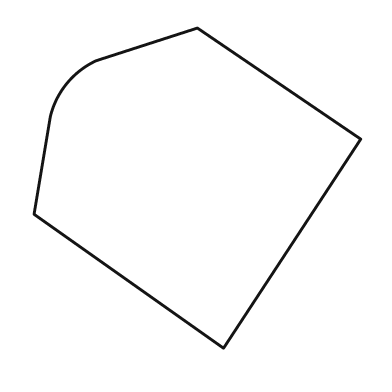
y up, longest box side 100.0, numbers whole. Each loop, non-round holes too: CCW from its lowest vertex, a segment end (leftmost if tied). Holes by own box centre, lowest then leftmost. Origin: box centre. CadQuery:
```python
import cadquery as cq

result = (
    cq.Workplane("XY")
    .moveTo(8.0, -49.0)
    .lineTo(50.0, 15.0)
    .lineTo(0.0, 49.0)
    .lineTo(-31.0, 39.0)
    .threePointArc((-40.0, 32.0), (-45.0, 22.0))
    .lineTo(-50.0, -8.0)
    .close()
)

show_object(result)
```